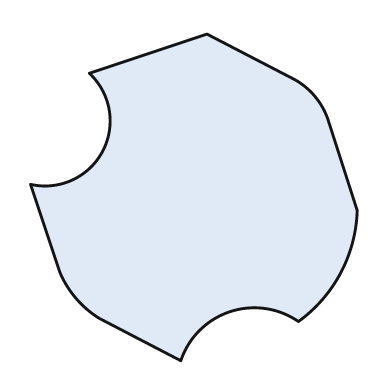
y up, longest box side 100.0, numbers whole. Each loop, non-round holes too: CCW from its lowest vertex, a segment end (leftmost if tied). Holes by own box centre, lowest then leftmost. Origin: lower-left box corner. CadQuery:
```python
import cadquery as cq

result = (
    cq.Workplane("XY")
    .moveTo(46.0, 0.0)
    .threePointArc((61.0, 15.0), (82.0, 12.0))
    .threePointArc((95.0, 27.0), (100.0, 46.0))
    .lineTo(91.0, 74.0)
    .threePointArc((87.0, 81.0), (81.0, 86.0))
    .lineTo(54.0, 100.0)
    .lineTo(18.0, 88.0)
    .threePointArc((22.0, 64.0), (0.0, 54.0))
    .lineTo(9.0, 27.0)
    .threePointArc((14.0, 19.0), (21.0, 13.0))
    .close()
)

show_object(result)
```